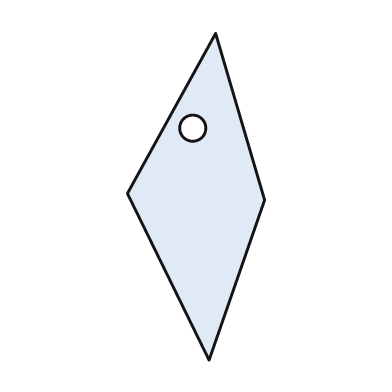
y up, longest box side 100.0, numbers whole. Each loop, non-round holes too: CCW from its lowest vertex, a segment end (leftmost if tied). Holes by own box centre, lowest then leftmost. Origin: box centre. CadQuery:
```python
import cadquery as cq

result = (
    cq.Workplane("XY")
    .moveTo(4.0, -50.0)
    .lineTo(21.0, -1.0)
    .lineTo(6.0, 50.0)
    .lineTo(-21.0, 1.0)
    .close()
    .moveTo(-1.0, 21.0)
    .circle(4.0)
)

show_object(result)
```